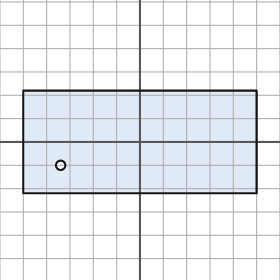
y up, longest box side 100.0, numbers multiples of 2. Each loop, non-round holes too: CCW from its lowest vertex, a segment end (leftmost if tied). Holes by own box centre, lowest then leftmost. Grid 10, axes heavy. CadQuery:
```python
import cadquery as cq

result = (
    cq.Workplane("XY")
    .moveTo(-50.0, -22.0)
    .lineTo(50.0, -22.0)
    .lineTo(50.0, 22.0)
    .lineTo(-50.0, 22.0)
    .close()
    .moveTo(-34.0, -10.0)
    .circle(2.0)
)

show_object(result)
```